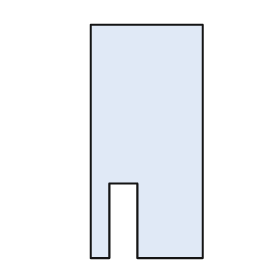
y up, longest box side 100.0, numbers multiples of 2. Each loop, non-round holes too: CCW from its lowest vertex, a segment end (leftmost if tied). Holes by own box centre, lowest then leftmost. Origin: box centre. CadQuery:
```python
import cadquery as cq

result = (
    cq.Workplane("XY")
    .moveTo(-24.0, -50.0)
    .lineTo(-16.0, -50.0)
    .lineTo(-16.0, -18.0)
    .lineTo(-4.0, -18.0)
    .lineTo(-4.0, -50.0)
    .lineTo(24.0, -50.0)
    .lineTo(24.0, 50.0)
    .lineTo(-24.0, 50.0)
    .close()
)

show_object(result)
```